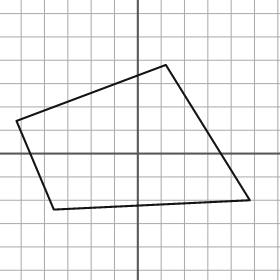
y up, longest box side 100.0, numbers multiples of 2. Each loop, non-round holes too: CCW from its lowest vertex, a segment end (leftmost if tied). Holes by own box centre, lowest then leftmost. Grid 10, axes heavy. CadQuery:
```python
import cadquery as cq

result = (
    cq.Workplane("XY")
    .moveTo(-36.0, -24.0)
    .lineTo(48.0, -20.0)
    .lineTo(12.0, 38.0)
    .lineTo(-52.0, 14.0)
    .close()
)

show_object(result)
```